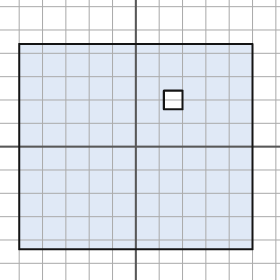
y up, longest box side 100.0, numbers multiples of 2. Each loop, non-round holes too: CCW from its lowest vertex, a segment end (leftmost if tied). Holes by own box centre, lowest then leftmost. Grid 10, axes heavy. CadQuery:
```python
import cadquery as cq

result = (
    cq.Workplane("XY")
    .moveTo(-50.0, -44.0)
    .lineTo(50.0, -44.0)
    .lineTo(50.0, 44.0)
    .lineTo(-50.0, 44.0)
    .close()
    .moveTo(12.0, 16.0)
    .lineTo(20.0, 16.0)
    .lineTo(20.0, 24.0)
    .lineTo(12.0, 24.0)
    .close()
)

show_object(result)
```